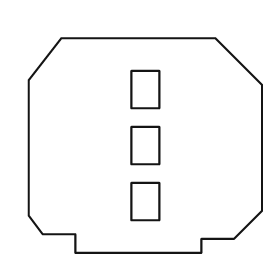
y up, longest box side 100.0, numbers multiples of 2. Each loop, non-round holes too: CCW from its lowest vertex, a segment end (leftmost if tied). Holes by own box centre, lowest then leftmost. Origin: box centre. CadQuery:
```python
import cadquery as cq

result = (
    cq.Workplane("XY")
    .moveTo(-30.0, -46.0)
    .lineTo(24.0, -46.0)
    .lineTo(24.0, -40.0)
    .lineTo(38.0, -40.0)
    .lineTo(50.0, -28.0)
    .lineTo(50.0, 26.0)
    .lineTo(30.0, 46.0)
    .lineTo(-36.0, 46.0)
    .lineTo(-50.0, 28.0)
    .lineTo(-50.0, -30.0)
    .lineTo(-44.0, -38.0)
    .lineTo(-30.0, -38.0)
    .close()
    .moveTo(-6.0, -32.0)
    .lineTo(6.0, -32.0)
    .lineTo(6.0, -16.0)
    .lineTo(-6.0, -16.0)
    .close()
    .moveTo(-6.0, -8.0)
    .lineTo(6.0, -8.0)
    .lineTo(6.0, 8.0)
    .lineTo(-6.0, 8.0)
    .close()
    .moveTo(-6.0, 16.0)
    .lineTo(6.0, 16.0)
    .lineTo(6.0, 32.0)
    .lineTo(-6.0, 32.0)
    .close()
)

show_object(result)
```